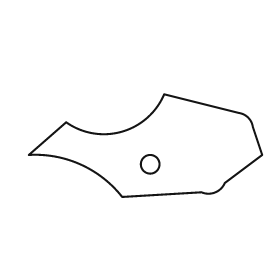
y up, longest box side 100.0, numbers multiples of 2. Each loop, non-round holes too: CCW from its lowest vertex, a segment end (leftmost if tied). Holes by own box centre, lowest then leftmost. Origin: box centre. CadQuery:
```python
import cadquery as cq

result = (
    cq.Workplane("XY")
    .moveTo(-10.0, -22.0)
    .lineTo(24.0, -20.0)
    .threePointArc((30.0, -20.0), (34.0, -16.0))
    .lineTo(50.0, -4.0)
    .lineTo(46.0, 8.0)
    .threePointArc((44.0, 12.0), (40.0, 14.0))
    .lineTo(8.0, 22.0)
    .threePointArc((-10.0, 6.0), (-34.0, 10.0))
    .lineTo(-50.0, -4.0)
    .threePointArc((-28.0, -8.0), (-10.0, -22.0))
    .close()
    .moveTo(2.0, -8.0)
    .circle(4.0)
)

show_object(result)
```